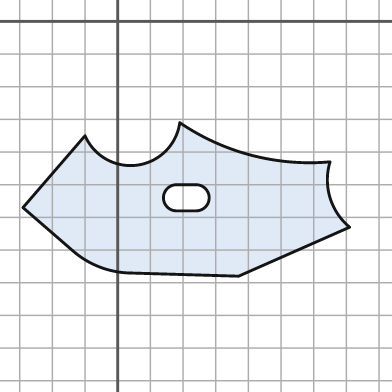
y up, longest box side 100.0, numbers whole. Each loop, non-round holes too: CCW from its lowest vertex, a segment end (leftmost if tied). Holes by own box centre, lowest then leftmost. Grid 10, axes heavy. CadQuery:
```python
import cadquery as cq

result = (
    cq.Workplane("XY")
    .moveTo(37.0, -78.0)
    .lineTo(71.0, -63.0)
    .threePointArc((65.0, -54.0), (65.0, -43.0))
    .threePointArc((41.0, -41.0), (19.0, -31.0))
    .threePointArc((6.0, -44.0), (-10.0, -35.0))
    .lineTo(-29.0, -57.0)
    .lineTo(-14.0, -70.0)
    .threePointArc((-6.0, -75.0), (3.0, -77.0))
    .close()
    .moveTo(18.0, -58.0)
    .lineTo(24.0, -58.0)
    .threePointArc((28.0, -54.0), (24.0, -50.0))
    .lineTo(18.0, -50.0)
    .threePointArc((14.0, -54.0), (18.0, -58.0))
    .close()
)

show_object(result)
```